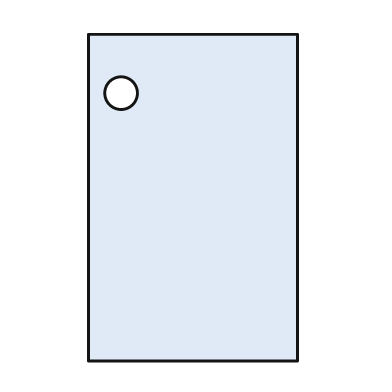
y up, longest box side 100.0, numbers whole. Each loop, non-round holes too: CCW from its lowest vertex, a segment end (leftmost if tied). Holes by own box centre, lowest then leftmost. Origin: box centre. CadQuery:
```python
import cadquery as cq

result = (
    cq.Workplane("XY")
    .moveTo(-32.0, -50.0)
    .lineTo(32.0, -50.0)
    .lineTo(32.0, 50.0)
    .lineTo(-32.0, 50.0)
    .close()
    .moveTo(-22.0, 32.0)
    .circle(5.0)
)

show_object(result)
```